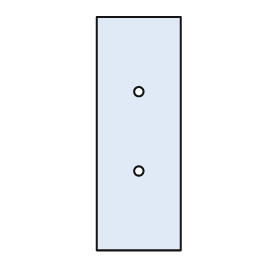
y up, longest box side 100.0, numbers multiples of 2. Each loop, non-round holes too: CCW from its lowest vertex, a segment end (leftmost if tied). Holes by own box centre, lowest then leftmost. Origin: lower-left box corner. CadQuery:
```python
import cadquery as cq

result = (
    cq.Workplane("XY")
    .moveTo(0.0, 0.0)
    .lineTo(36.0, 0.0)
    .lineTo(36.0, 100.0)
    .lineTo(0.0, 100.0)
    .close()
    .moveTo(18.0, 34.0)
    .circle(2.0)
    .moveTo(18.0, 68.0)
    .circle(2.0)
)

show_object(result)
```